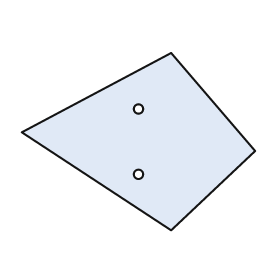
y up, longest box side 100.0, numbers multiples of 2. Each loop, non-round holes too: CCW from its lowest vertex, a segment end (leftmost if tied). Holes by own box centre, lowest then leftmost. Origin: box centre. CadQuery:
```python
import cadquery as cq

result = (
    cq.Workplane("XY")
    .moveTo(14.0, -38.0)
    .lineTo(50.0, -4.0)
    .lineTo(14.0, 38.0)
    .lineTo(-50.0, 4.0)
    .close()
    .moveTo(0.0, -14.0)
    .circle(2.0)
    .moveTo(0.0, 14.0)
    .circle(2.0)
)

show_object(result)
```